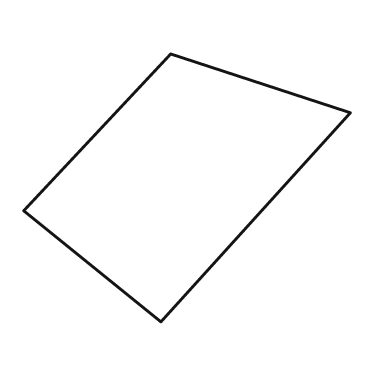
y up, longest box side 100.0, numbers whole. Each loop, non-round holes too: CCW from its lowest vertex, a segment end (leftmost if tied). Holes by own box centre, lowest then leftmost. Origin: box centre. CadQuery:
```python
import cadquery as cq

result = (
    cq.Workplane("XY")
    .moveTo(-8.0, -41.0)
    .lineTo(50.0, 23.0)
    .lineTo(-5.0, 41.0)
    .lineTo(-50.0, -7.0)
    .close()
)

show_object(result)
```